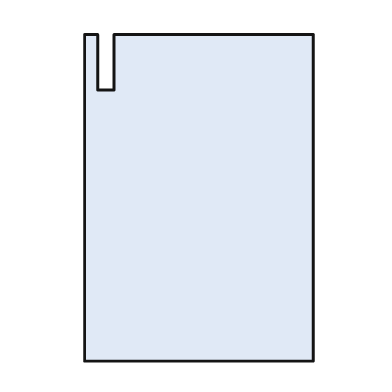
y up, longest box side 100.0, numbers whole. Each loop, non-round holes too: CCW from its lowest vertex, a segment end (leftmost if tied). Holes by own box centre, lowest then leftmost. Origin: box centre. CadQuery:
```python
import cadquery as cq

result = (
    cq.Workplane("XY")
    .moveTo(-35.0, -50.0)
    .lineTo(35.0, -50.0)
    .lineTo(35.0, 50.0)
    .lineTo(-26.0, 50.0)
    .lineTo(-26.0, 33.0)
    .lineTo(-31.0, 33.0)
    .lineTo(-31.0, 50.0)
    .lineTo(-35.0, 50.0)
    .close()
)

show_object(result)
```